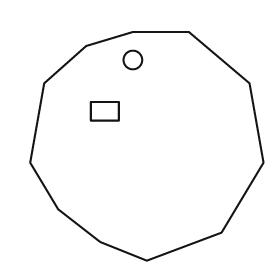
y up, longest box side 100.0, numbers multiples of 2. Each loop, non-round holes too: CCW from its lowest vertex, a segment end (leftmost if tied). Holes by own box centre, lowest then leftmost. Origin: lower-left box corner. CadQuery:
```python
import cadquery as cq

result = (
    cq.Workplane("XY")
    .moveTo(50.0, 0.0)
    .lineTo(82.0, 12.0)
    .lineTo(100.0, 42.0)
    .lineTo(94.0, 76.0)
    .lineTo(68.0, 98.0)
    .lineTo(44.0, 98.0)
    .lineTo(24.0, 92.0)
    .lineTo(6.0, 76.0)
    .lineTo(0.0, 42.0)
    .lineTo(12.0, 22.0)
    .lineTo(30.0, 8.0)
    .close()
    .moveTo(26.0, 60.0)
    .lineTo(38.0, 60.0)
    .lineTo(38.0, 68.0)
    .lineTo(26.0, 68.0)
    .close()
    .moveTo(44.0, 86.0)
    .circle(4.0)
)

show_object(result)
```